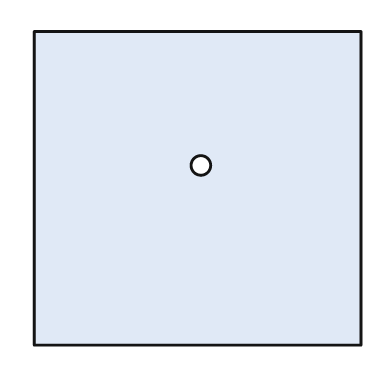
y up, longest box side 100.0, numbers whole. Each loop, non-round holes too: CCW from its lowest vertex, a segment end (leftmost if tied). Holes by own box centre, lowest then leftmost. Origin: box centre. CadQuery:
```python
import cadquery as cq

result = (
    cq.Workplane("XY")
    .moveTo(-50.0, -48.0)
    .lineTo(50.0, -48.0)
    .lineTo(50.0, 48.0)
    .lineTo(-50.0, 48.0)
    .close()
    .moveTo(1.0, 7.0)
    .circle(3.0)
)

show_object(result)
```